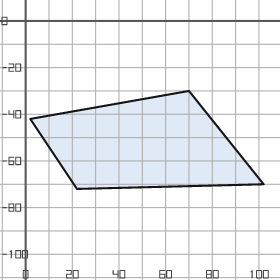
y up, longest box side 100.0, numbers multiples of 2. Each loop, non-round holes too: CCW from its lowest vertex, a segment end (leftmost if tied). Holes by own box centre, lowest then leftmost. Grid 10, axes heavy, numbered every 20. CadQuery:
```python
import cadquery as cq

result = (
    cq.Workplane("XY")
    .moveTo(22.0, -72.0)
    .lineTo(102.0, -70.0)
    .lineTo(70.0, -30.0)
    .lineTo(2.0, -42.0)
    .close()
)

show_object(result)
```